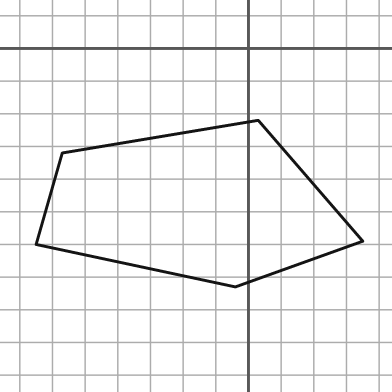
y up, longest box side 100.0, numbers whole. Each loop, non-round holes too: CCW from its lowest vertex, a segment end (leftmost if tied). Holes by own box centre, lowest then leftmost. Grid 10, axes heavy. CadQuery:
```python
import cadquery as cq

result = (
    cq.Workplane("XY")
    .moveTo(-4.0, -73.0)
    .lineTo(35.0, -59.0)
    .lineTo(3.0, -22.0)
    .lineTo(-57.0, -32.0)
    .lineTo(-65.0, -60.0)
    .close()
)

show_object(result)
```